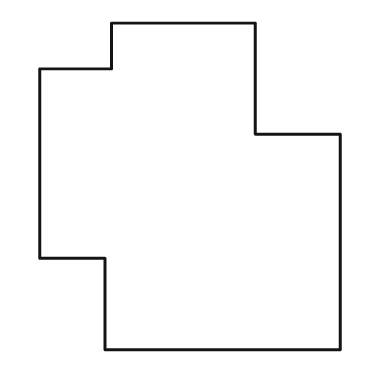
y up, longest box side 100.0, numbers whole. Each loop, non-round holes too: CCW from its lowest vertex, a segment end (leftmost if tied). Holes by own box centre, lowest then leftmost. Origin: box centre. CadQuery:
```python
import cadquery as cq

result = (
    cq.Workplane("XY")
    .moveTo(-26.0, -50.0)
    .lineTo(46.0, -50.0)
    .lineTo(46.0, 16.0)
    .lineTo(20.0, 16.0)
    .lineTo(20.0, 50.0)
    .lineTo(-24.0, 50.0)
    .lineTo(-24.0, 36.0)
    .lineTo(-46.0, 36.0)
    .lineTo(-46.0, -22.0)
    .lineTo(-26.0, -22.0)
    .close()
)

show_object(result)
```